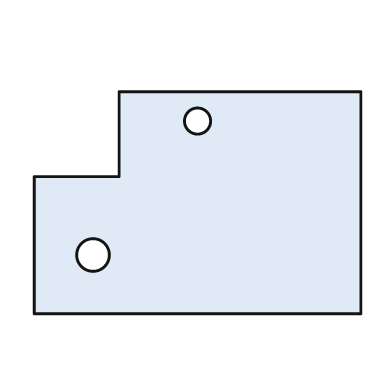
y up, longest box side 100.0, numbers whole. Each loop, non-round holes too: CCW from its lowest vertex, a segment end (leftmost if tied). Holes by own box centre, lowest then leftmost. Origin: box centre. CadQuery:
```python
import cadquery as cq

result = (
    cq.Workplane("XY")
    .moveTo(-50.0, -34.0)
    .lineTo(50.0, -34.0)
    .lineTo(50.0, 34.0)
    .lineTo(-24.0, 34.0)
    .lineTo(-24.0, 8.0)
    .lineTo(-50.0, 8.0)
    .close()
    .moveTo(-32.0, -16.0)
    .circle(5.0)
    .moveTo(0.0, 25.0)
    .circle(4.0)
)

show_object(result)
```